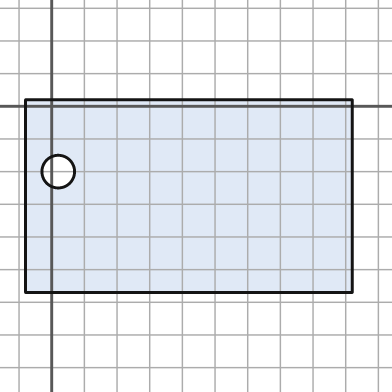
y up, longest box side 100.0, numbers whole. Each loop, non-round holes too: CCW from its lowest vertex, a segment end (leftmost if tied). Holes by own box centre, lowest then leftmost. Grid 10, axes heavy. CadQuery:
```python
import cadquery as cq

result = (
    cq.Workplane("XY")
    .moveTo(-8.0, -57.0)
    .lineTo(92.0, -57.0)
    .lineTo(92.0, 2.0)
    .lineTo(-8.0, 2.0)
    .close()
    .moveTo(2.0, -20.0)
    .circle(5.0)
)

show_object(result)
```